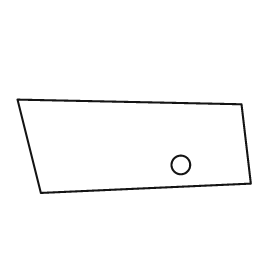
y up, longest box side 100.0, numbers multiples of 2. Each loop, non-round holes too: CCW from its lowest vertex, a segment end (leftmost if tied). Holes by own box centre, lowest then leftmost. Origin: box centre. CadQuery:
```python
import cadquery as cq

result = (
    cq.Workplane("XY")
    .moveTo(-40.0, -20.0)
    .lineTo(50.0, -16.0)
    .lineTo(46.0, 18.0)
    .lineTo(-50.0, 20.0)
    .close()
    .moveTo(20.0, -8.0)
    .circle(4.0)
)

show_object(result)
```